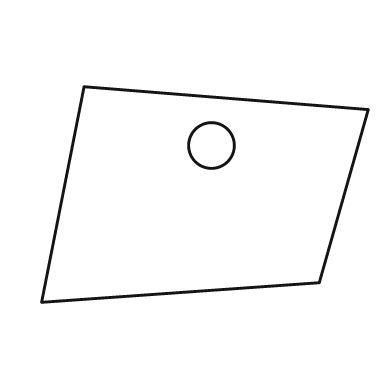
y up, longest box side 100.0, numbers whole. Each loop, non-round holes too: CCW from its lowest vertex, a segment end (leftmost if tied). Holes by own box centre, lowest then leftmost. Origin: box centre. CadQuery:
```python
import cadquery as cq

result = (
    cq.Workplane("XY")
    .moveTo(-50.0, -33.0)
    .lineTo(35.0, -27.0)
    .lineTo(50.0, 26.0)
    .lineTo(-37.0, 33.0)
    .close()
    .moveTo(2.0, 15.0)
    .circle(7.0)
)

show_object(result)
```